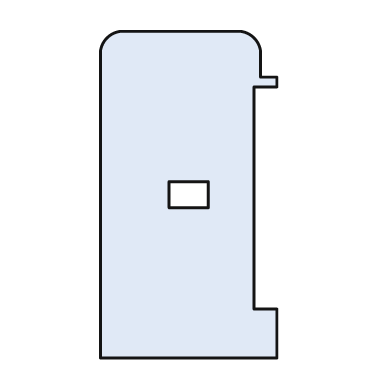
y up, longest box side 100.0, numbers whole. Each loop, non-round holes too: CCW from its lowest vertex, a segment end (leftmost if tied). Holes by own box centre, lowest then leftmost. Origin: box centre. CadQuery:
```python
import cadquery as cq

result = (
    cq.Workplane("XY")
    .moveTo(-27.0, -50.0)
    .lineTo(27.0, -50.0)
    .lineTo(27.0, -35.0)
    .lineTo(20.0, -35.0)
    .lineTo(20.0, 33.0)
    .lineTo(27.0, 33.0)
    .lineTo(27.0, 36.0)
    .lineTo(22.0, 36.0)
    .lineTo(22.0, 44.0)
    .threePointArc((20.0, 48.0), (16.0, 50.0))
    .lineTo(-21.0, 50.0)
    .threePointArc((-25.0, 48.0), (-27.0, 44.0))
    .close()
    .moveTo(-6.0, -4.0)
    .lineTo(6.0, -4.0)
    .lineTo(6.0, 4.0)
    .lineTo(-6.0, 4.0)
    .close()
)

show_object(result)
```